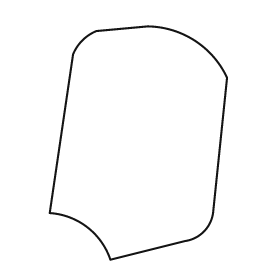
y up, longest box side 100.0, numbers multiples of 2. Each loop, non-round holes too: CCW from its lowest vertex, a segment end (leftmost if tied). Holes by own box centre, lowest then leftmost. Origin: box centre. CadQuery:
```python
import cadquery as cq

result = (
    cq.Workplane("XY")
    .moveTo(-12.0, -50.0)
    .lineTo(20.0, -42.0)
    .threePointArc((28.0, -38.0), (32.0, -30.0))
    .lineTo(38.0, 28.0)
    .threePointArc((24.0, 44.0), (4.0, 50.0))
    .lineTo(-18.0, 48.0)
    .threePointArc((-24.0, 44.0), (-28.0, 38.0))
    .lineTo(-38.0, -30.0)
    .threePointArc((-22.0, -36.0), (-12.0, -50.0))
    .close()
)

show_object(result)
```